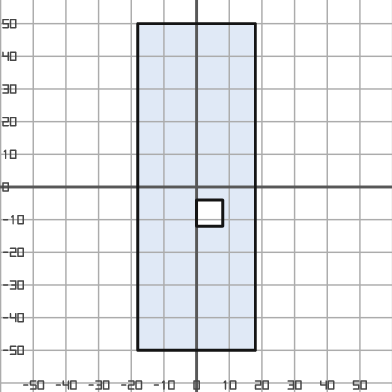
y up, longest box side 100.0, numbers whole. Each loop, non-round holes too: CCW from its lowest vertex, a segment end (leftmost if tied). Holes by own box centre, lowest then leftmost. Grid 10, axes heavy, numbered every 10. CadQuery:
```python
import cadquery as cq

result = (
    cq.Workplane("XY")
    .moveTo(-18.0, -50.0)
    .lineTo(18.0, -50.0)
    .lineTo(18.0, 50.0)
    .lineTo(-18.0, 50.0)
    .close()
    .moveTo(0.0, -12.0)
    .lineTo(8.0, -12.0)
    .lineTo(8.0, -4.0)
    .lineTo(0.0, -4.0)
    .close()
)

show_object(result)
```